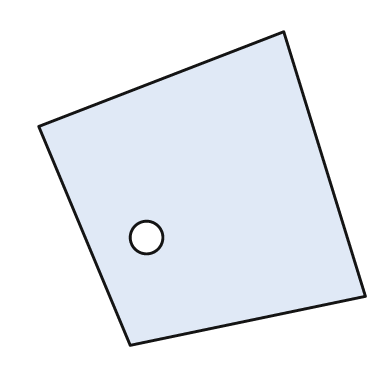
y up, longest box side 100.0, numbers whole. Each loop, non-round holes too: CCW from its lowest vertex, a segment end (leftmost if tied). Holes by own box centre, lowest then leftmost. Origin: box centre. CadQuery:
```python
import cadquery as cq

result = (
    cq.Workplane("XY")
    .moveTo(-22.0, -48.0)
    .lineTo(50.0, -33.0)
    .lineTo(25.0, 48.0)
    .lineTo(-50.0, 19.0)
    .close()
    .moveTo(-17.0, -15.0)
    .circle(5.0)
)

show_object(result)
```